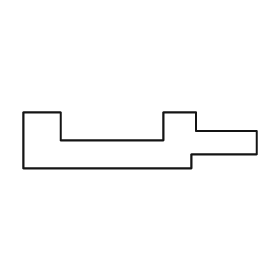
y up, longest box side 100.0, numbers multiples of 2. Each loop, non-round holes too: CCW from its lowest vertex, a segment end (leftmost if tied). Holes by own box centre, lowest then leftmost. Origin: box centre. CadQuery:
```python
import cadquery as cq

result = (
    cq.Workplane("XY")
    .moveTo(-50.0, -12.0)
    .lineTo(22.0, -12.0)
    .lineTo(22.0, -6.0)
    .lineTo(50.0, -6.0)
    .lineTo(50.0, 4.0)
    .lineTo(24.0, 4.0)
    .lineTo(24.0, 12.0)
    .lineTo(10.0, 12.0)
    .lineTo(10.0, 0.0)
    .lineTo(-34.0, 0.0)
    .lineTo(-34.0, 12.0)
    .lineTo(-50.0, 12.0)
    .close()
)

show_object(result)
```